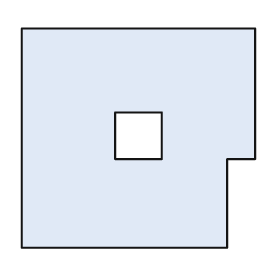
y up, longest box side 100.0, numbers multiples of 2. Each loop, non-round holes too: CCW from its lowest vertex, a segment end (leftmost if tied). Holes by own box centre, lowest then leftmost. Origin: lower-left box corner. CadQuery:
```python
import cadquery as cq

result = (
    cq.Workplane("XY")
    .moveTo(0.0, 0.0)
    .lineTo(88.0, 0.0)
    .lineTo(88.0, 38.0)
    .lineTo(100.0, 38.0)
    .lineTo(100.0, 94.0)
    .lineTo(0.0, 94.0)
    .close()
    .moveTo(40.0, 38.0)
    .lineTo(60.0, 38.0)
    .lineTo(60.0, 58.0)
    .lineTo(40.0, 58.0)
    .close()
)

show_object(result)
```